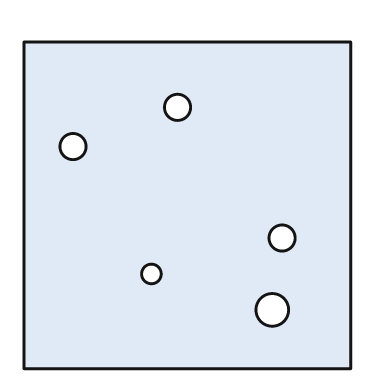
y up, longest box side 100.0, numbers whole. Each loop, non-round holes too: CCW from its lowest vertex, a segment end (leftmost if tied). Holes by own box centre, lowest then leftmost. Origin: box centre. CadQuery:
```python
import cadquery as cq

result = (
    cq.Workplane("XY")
    .moveTo(-50.0, -50.0)
    .lineTo(50.0, -50.0)
    .lineTo(50.0, 50.0)
    .lineTo(-50.0, 50.0)
    .close()
    .moveTo(26.0, -32.0)
    .circle(5.0)
    .moveTo(-11.0, -21.0)
    .circle(3.0)
    .moveTo(29.0, -10.0)
    .circle(4.0)
    .moveTo(-35.0, 18.0)
    .circle(4.0)
    .moveTo(-3.0, 30.0)
    .circle(4.0)
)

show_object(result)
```